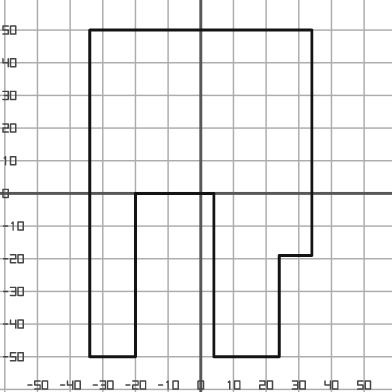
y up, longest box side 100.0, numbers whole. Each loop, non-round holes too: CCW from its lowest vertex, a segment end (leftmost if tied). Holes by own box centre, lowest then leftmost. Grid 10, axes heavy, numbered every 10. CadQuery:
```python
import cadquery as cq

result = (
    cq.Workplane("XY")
    .moveTo(-34.0, -50.0)
    .lineTo(-20.0, -50.0)
    .lineTo(-20.0, 0.0)
    .lineTo(4.0, 0.0)
    .lineTo(4.0, -50.0)
    .lineTo(24.0, -50.0)
    .lineTo(24.0, -19.0)
    .lineTo(34.0, -19.0)
    .lineTo(34.0, 50.0)
    .lineTo(-34.0, 50.0)
    .close()
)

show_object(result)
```